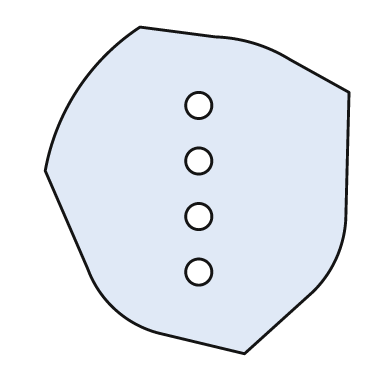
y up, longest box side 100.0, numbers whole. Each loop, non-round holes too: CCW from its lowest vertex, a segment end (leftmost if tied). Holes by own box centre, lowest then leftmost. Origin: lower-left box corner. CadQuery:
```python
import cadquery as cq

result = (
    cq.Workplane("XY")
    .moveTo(61.0, 0.0)
    .lineTo(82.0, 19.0)
    .threePointArc((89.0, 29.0), (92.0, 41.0))
    .lineTo(93.0, 80.0)
    .lineTo(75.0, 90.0)
    .threePointArc((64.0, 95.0), (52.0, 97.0))
    .lineTo(29.0, 100.0)
    .threePointArc((10.0, 81.0), (0.0, 56.0))
    .lineTo(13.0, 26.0)
    .threePointArc((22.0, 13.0), (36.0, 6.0))
    .close()
    .moveTo(47.0, 25.0)
    .circle(4.0)
    .moveTo(47.0, 42.0)
    .circle(4.0)
    .moveTo(47.0, 59.0)
    .circle(4.0)
    .moveTo(47.0, 76.0)
    .circle(4.0)
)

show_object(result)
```